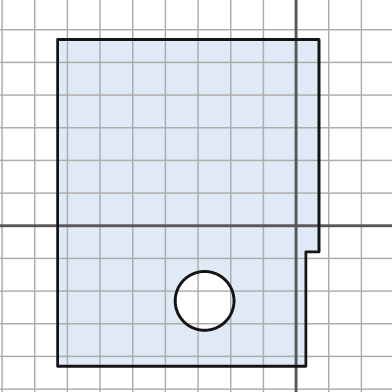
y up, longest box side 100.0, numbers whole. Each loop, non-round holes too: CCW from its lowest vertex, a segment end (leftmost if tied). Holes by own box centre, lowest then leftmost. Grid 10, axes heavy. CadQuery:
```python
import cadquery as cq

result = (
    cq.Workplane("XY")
    .moveTo(-73.0, -43.0)
    .lineTo(3.0, -43.0)
    .lineTo(3.0, -8.0)
    .lineTo(7.0, -8.0)
    .lineTo(7.0, 57.0)
    .lineTo(-73.0, 57.0)
    .close()
    .moveTo(-28.0, -23.0)
    .circle(9.0)
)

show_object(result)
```